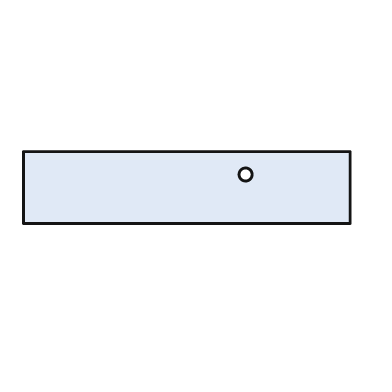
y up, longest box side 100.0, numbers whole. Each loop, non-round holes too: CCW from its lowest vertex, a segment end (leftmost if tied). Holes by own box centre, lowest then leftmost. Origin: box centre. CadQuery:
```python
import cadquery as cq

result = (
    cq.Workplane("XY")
    .moveTo(-50.0, -11.0)
    .lineTo(50.0, -11.0)
    .lineTo(50.0, 11.0)
    .lineTo(-50.0, 11.0)
    .close()
    .moveTo(18.0, 4.0)
    .circle(2.0)
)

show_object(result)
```